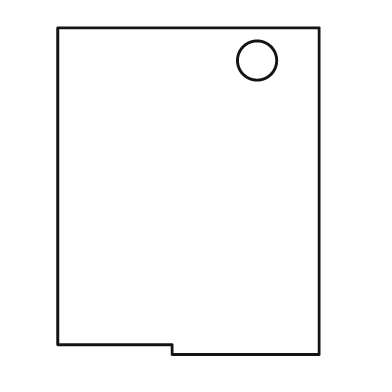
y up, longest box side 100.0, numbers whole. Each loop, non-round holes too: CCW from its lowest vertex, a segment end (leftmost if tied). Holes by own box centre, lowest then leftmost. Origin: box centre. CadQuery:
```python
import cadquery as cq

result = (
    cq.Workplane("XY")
    .moveTo(-5.0, -50.0)
    .lineTo(40.0, -50.0)
    .lineTo(40.0, 50.0)
    .lineTo(-40.0, 50.0)
    .lineTo(-40.0, -47.0)
    .lineTo(-5.0, -47.0)
    .close()
    .moveTo(21.0, 40.0)
    .circle(6.0)
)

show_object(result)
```